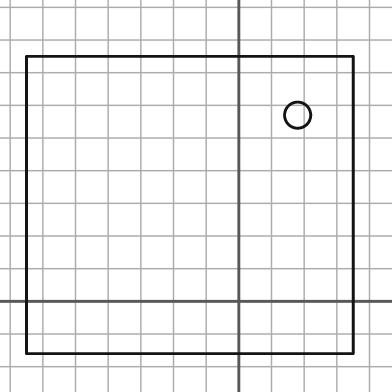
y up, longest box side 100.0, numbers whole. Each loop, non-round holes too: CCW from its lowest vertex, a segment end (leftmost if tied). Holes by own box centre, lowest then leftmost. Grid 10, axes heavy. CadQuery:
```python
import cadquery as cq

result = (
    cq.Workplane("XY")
    .moveTo(-65.0, -16.0)
    .lineTo(35.0, -16.0)
    .lineTo(35.0, 75.0)
    .lineTo(-65.0, 75.0)
    .close()
    .moveTo(18.0, 57.0)
    .circle(4.0)
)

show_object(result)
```